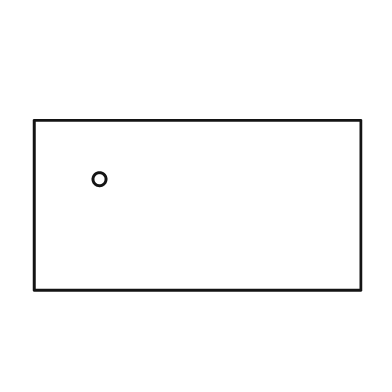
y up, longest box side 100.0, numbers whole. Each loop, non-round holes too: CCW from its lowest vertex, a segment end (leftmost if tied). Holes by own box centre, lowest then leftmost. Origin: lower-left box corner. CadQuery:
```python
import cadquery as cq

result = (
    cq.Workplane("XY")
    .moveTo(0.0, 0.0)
    .lineTo(100.0, 0.0)
    .lineTo(100.0, 52.0)
    .lineTo(0.0, 52.0)
    .close()
    .moveTo(20.0, 34.0)
    .circle(2.0)
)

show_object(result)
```